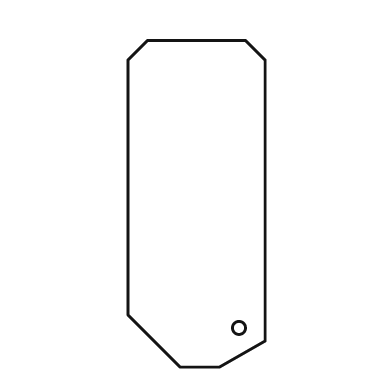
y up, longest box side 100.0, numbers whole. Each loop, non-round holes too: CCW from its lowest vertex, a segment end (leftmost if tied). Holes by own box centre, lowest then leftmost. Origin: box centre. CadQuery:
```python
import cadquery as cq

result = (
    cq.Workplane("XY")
    .moveTo(-5.0, -50.0)
    .lineTo(7.0, -50.0)
    .lineTo(21.0, -42.0)
    .lineTo(21.0, 44.0)
    .lineTo(15.0, 50.0)
    .lineTo(-15.0, 50.0)
    .lineTo(-21.0, 44.0)
    .lineTo(-21.0, -34.0)
    .close()
    .moveTo(13.0, -38.0)
    .circle(2.0)
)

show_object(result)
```